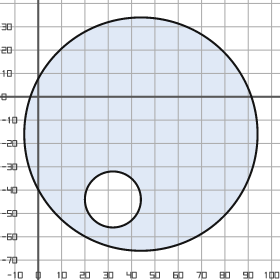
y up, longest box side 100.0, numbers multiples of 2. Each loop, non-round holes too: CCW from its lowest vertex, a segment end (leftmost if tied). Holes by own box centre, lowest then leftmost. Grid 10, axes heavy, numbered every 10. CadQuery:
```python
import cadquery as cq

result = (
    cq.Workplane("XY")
    .moveTo(44.0, -16.0)
    .circle(50.0)
    .moveTo(32.0, -44.0)
    .circle(12.0)
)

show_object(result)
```